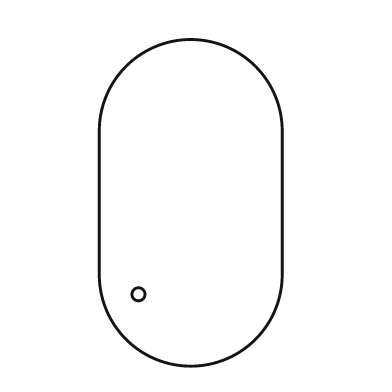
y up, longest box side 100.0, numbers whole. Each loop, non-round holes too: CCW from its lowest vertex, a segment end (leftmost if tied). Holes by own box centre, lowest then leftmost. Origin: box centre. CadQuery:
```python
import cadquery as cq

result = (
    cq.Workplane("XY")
    .moveTo(-28.0, -22.0)
    .threePointArc((0.0, -50.0), (28.0, -22.0))
    .lineTo(28.0, 22.0)
    .threePointArc((0.0, 50.0), (-28.0, 22.0))
    .close()
    .moveTo(-16.0, -28.0)
    .circle(2.0)
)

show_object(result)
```